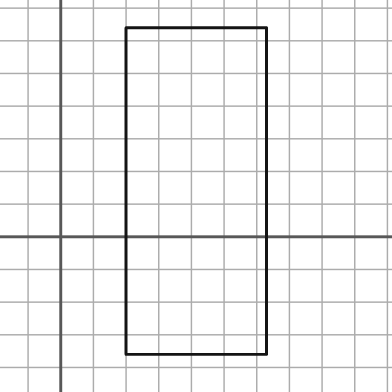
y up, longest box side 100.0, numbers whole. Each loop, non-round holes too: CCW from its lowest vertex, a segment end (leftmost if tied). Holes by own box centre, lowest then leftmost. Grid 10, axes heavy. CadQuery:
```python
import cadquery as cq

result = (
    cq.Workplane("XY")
    .moveTo(20.0, -36.0)
    .lineTo(63.0, -36.0)
    .lineTo(63.0, 64.0)
    .lineTo(20.0, 64.0)
    .close()
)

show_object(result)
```